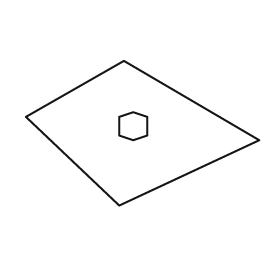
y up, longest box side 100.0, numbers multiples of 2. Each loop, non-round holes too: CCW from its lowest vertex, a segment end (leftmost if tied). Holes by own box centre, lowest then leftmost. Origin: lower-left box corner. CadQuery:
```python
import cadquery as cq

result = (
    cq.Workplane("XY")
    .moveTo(40.0, 0.0)
    .lineTo(100.0, 28.0)
    .lineTo(42.0, 62.0)
    .lineTo(0.0, 38.0)
    .close()
    .moveTo(46.0, 28.0)
    .lineTo(52.0, 30.0)
    .lineTo(52.0, 38.0)
    .lineTo(46.0, 40.0)
    .lineTo(40.0, 38.0)
    .lineTo(40.0, 30.0)
    .close()
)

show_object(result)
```